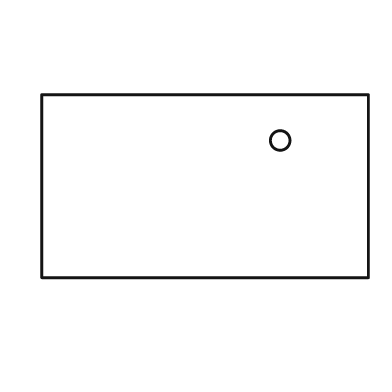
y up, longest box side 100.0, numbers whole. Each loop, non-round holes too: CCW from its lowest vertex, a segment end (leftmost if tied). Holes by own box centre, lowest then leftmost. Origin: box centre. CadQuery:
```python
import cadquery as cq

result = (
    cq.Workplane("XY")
    .moveTo(-50.0, -28.0)
    .lineTo(50.0, -28.0)
    .lineTo(50.0, 28.0)
    .lineTo(-50.0, 28.0)
    .close()
    .moveTo(23.0, 14.0)
    .circle(3.0)
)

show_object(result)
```